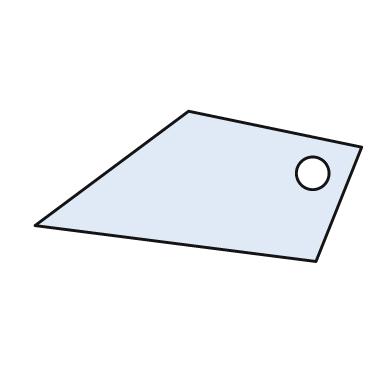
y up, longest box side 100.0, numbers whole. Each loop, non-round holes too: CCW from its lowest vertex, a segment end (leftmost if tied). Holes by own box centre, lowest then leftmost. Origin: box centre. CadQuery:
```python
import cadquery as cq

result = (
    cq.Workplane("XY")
    .moveTo(36.0, -23.0)
    .lineTo(50.0, 12.0)
    .lineTo(-3.0, 23.0)
    .lineTo(-50.0, -12.0)
    .close()
    .moveTo(35.0, 4.0)
    .circle(5.0)
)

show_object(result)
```